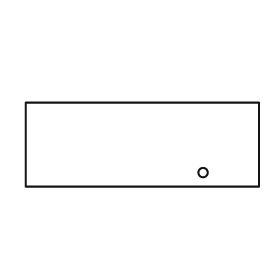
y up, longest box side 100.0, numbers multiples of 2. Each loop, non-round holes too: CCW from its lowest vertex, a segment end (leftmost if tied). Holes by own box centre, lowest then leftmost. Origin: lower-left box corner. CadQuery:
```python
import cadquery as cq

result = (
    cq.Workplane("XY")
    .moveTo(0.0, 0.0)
    .lineTo(100.0, 0.0)
    .lineTo(100.0, 36.0)
    .lineTo(0.0, 36.0)
    .close()
    .moveTo(76.0, 6.0)
    .circle(2.0)
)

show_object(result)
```